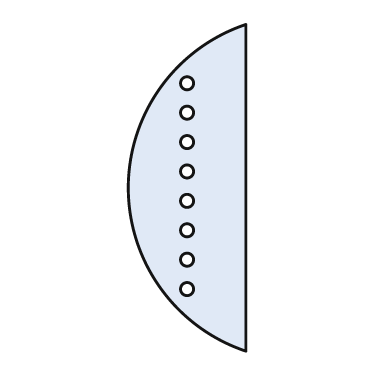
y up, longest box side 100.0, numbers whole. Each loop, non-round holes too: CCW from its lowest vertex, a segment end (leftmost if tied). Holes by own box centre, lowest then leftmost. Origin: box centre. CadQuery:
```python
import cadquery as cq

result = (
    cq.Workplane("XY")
    .moveTo(18.0, -50.0)
    .lineTo(18.0, 50.0)
    .threePointArc((-18.0, 0.0), (18.0, -50.0))
    .close()
    .moveTo(0.0, -31.0)
    .circle(2.0)
    .moveTo(0.0, -22.0)
    .circle(2.0)
    .moveTo(0.0, -13.0)
    .circle(2.0)
    .moveTo(0.0, -4.0)
    .circle(2.0)
    .moveTo(0.0, 5.0)
    .circle(2.0)
    .moveTo(0.0, 14.0)
    .circle(2.0)
    .moveTo(0.0, 23.0)
    .circle(2.0)
    .moveTo(0.0, 32.0)
    .circle(2.0)
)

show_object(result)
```